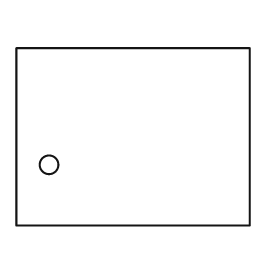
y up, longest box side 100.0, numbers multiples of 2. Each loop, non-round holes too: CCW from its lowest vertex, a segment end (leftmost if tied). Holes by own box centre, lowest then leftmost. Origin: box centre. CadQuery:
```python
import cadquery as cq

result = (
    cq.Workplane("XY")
    .moveTo(-50.0, -38.0)
    .lineTo(50.0, -38.0)
    .lineTo(50.0, 38.0)
    .lineTo(-50.0, 38.0)
    .close()
    .moveTo(-36.0, -12.0)
    .circle(4.0)
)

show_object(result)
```